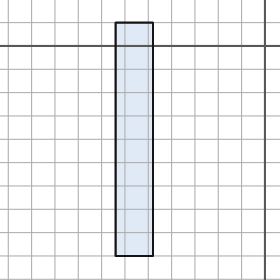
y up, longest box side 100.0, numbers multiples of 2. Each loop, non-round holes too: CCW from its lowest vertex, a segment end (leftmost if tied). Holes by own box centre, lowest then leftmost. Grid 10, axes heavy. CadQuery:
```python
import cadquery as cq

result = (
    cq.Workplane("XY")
    .moveTo(-64.0, -90.0)
    .lineTo(-48.0, -90.0)
    .lineTo(-48.0, 10.0)
    .lineTo(-64.0, 10.0)
    .close()
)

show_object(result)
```